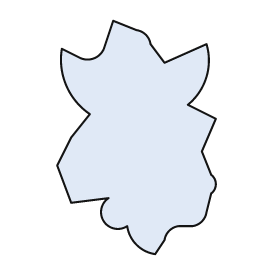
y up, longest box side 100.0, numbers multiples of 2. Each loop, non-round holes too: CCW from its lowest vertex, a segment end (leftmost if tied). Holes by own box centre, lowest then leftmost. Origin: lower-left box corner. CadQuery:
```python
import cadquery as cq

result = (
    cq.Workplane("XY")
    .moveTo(42.0, 0.0)
    .lineTo(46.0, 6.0)
    .threePointArc((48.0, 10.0), (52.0, 12.0))
    .lineTo(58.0, 12.0)
    .threePointArc((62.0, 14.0), (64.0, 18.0))
    .lineTo(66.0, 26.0)
    .threePointArc((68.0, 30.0), (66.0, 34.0))
    .lineTo(62.0, 44.0)
    .lineTo(68.0, 58.0)
    .lineTo(56.0, 64.0)
    .threePointArc((64.0, 76.0), (64.0, 90.0))
    .lineTo(46.0, 82.0)
    .lineTo(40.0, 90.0)
    .threePointArc((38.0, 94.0), (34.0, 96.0))
    .lineTo(24.0, 100.0)
    .lineTo(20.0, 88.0)
    .threePointArc((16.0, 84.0), (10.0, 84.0))
    .lineTo(2.0, 88.0)
    .threePointArc((4.0, 72.0), (14.0, 60.0))
    .lineTo(6.0, 50.0)
    .lineTo(0.0, 38.0)
    .lineTo(6.0, 22.0)
    .lineTo(22.0, 24.0)
    .threePointArc((20.0, 14.0), (30.0, 12.0))
    .threePointArc((34.0, 4.0), (42.0, 0.0))
    .close()
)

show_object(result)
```